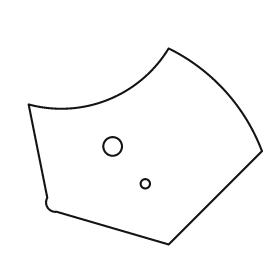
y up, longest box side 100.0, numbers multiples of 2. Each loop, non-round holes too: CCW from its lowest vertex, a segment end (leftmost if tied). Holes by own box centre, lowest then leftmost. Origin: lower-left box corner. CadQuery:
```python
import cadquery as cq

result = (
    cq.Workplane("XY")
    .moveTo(60.0, 0.0)
    .lineTo(100.0, 40.0)
    .threePointArc((84.0, 66.0), (60.0, 84.0))
    .threePointArc((34.0, 62.0), (0.0, 60.0))
    .lineTo(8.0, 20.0)
    .threePointArc((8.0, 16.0), (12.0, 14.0))
    .close()
    .moveTo(50.0, 26.0)
    .circle(2.0)
    .moveTo(36.0, 42.0)
    .circle(4.0)
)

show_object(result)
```